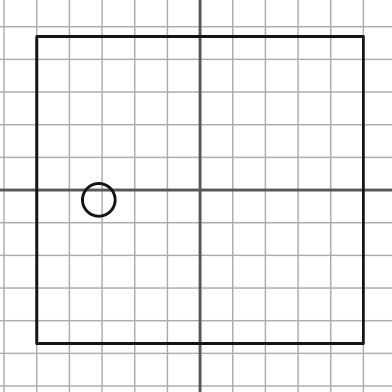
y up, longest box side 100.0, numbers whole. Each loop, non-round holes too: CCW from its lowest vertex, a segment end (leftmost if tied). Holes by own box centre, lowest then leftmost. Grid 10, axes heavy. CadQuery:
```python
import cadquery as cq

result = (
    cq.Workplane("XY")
    .moveTo(-50.0, -47.0)
    .lineTo(50.0, -47.0)
    .lineTo(50.0, 47.0)
    .lineTo(-50.0, 47.0)
    .close()
    .moveTo(-31.0, -3.0)
    .circle(5.0)
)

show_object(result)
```